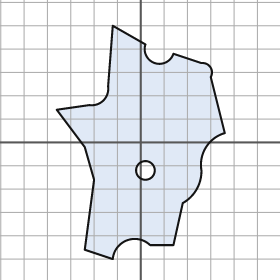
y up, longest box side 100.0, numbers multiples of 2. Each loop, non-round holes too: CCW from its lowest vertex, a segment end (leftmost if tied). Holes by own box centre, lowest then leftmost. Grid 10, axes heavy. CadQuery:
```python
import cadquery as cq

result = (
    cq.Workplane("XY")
    .moveTo(-12.0, -50.0)
    .threePointArc((-6.0, -42.0), (4.0, -44.0))
    .lineTo(14.0, -44.0)
    .lineTo(18.0, -26.0)
    .threePointArc((24.0, -20.0), (26.0, -12.0))
    .threePointArc((28.0, -2.0), (36.0, 4.0))
    .lineTo(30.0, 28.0)
    .threePointArc((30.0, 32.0), (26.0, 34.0))
    .lineTo(14.0, 38.0)
    .threePointArc((6.0, 34.0), (2.0, 42.0))
    .lineTo(-12.0, 50.0)
    .lineTo(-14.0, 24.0)
    .threePointArc((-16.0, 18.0), (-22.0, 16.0))
    .lineTo(-36.0, 14.0)
    .lineTo(-24.0, -2.0)
    .lineTo(-20.0, -16.0)
    .lineTo(-24.0, -46.0)
    .close()
    .moveTo(2.0, -12.0)
    .circle(4.0)
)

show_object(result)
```